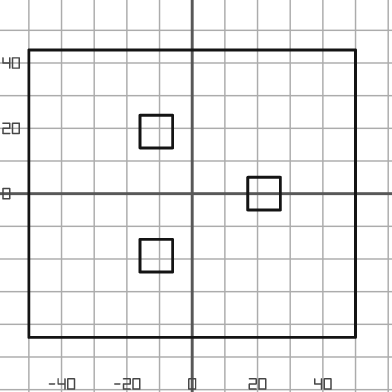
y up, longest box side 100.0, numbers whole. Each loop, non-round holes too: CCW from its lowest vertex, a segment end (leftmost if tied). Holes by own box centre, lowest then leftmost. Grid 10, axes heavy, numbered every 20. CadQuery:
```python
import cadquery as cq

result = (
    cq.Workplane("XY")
    .moveTo(-50.0, -44.0)
    .lineTo(50.0, -44.0)
    .lineTo(50.0, 44.0)
    .lineTo(-50.0, 44.0)
    .close()
    .moveTo(-16.0, -24.0)
    .lineTo(-6.0, -24.0)
    .lineTo(-6.0, -14.0)
    .lineTo(-16.0, -14.0)
    .close()
    .moveTo(17.0, -5.0)
    .lineTo(27.0, -5.0)
    .lineTo(27.0, 5.0)
    .lineTo(17.0, 5.0)
    .close()
    .moveTo(-16.0, 14.0)
    .lineTo(-6.0, 14.0)
    .lineTo(-6.0, 24.0)
    .lineTo(-16.0, 24.0)
    .close()
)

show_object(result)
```